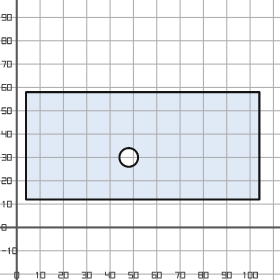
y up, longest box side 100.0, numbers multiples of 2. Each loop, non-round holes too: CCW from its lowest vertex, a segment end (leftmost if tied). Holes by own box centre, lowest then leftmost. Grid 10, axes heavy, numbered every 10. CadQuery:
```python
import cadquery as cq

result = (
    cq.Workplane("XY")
    .moveTo(4.0, 12.0)
    .lineTo(104.0, 12.0)
    .lineTo(104.0, 58.0)
    .lineTo(4.0, 58.0)
    .close()
    .moveTo(48.0, 30.0)
    .circle(4.0)
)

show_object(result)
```